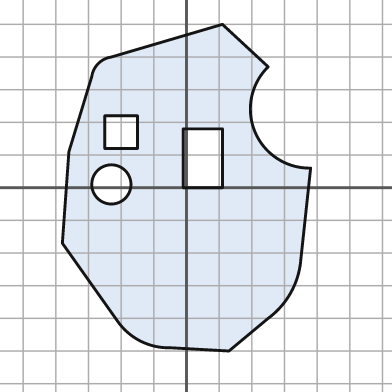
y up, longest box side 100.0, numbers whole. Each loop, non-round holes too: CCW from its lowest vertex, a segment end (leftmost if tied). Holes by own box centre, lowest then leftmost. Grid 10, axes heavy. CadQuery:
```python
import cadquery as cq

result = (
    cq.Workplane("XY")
    .moveTo(13.0, -50.0)
    .lineTo(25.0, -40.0)
    .threePointArc((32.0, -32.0), (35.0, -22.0))
    .lineTo(38.0, 6.0)
    .threePointArc((21.0, 17.0), (25.0, 37.0))
    .lineTo(11.0, 50.0)
    .lineTo(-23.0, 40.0)
    .threePointArc((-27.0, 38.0), (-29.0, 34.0))
    .lineTo(-36.0, 11.0)
    .lineTo(-38.0, -17.0)
    .lineTo(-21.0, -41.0)
    .threePointArc((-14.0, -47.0), (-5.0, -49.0))
    .close()
    .moveTo(-23.0, 1.0)
    .circle(6.0)
    .moveTo(-1.0, 0.0)
    .lineTo(11.0, 0.0)
    .lineTo(11.0, 18.0)
    .lineTo(-1.0, 18.0)
    .close()
    .moveTo(-25.0, 12.0)
    .lineTo(-15.0, 12.0)
    .lineTo(-15.0, 22.0)
    .lineTo(-25.0, 22.0)
    .close()
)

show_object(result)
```